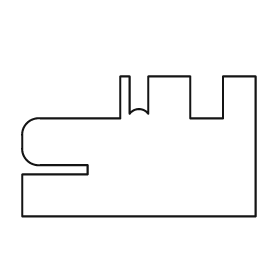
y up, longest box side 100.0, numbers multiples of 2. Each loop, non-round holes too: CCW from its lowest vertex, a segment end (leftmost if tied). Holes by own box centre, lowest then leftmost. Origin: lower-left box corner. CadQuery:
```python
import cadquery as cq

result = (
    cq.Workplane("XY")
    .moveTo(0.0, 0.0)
    .lineTo(100.0, 0.0)
    .lineTo(100.0, 60.0)
    .lineTo(86.0, 60.0)
    .lineTo(86.0, 42.0)
    .lineTo(72.0, 42.0)
    .lineTo(72.0, 60.0)
    .lineTo(54.0, 60.0)
    .lineTo(54.0, 44.0)
    .threePointArc((50.0, 46.0), (46.0, 44.0))
    .lineTo(46.0, 60.0)
    .lineTo(42.0, 60.0)
    .lineTo(42.0, 42.0)
    .lineTo(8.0, 42.0)
    .threePointArc((2.0, 40.0), (0.0, 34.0))
    .lineTo(0.0, 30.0)
    .threePointArc((2.0, 24.0), (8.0, 22.0))
    .lineTo(28.0, 22.0)
    .lineTo(28.0, 18.0)
    .lineTo(0.0, 18.0)
    .close()
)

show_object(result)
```